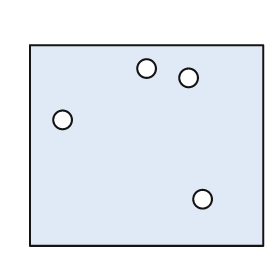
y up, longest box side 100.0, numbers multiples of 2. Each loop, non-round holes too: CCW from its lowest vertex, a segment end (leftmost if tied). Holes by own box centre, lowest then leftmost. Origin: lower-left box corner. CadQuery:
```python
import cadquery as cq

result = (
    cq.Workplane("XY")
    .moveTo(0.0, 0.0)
    .lineTo(100.0, 0.0)
    .lineTo(100.0, 86.0)
    .lineTo(0.0, 86.0)
    .close()
    .moveTo(74.0, 20.0)
    .circle(4.0)
    .moveTo(14.0, 54.0)
    .circle(4.0)
    .moveTo(68.0, 72.0)
    .circle(4.0)
    .moveTo(50.0, 76.0)
    .circle(4.0)
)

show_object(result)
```